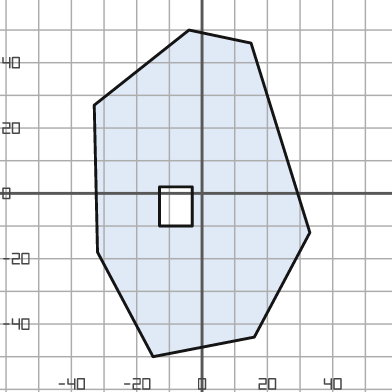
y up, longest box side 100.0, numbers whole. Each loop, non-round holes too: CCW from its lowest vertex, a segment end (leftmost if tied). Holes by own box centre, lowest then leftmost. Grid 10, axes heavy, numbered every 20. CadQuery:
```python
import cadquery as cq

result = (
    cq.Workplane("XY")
    .moveTo(-15.0, -50.0)
    .lineTo(16.0, -44.0)
    .lineTo(33.0, -12.0)
    .lineTo(15.0, 46.0)
    .lineTo(-4.0, 50.0)
    .lineTo(-33.0, 27.0)
    .lineTo(-32.0, -18.0)
    .close()
    .moveTo(-13.0, -10.0)
    .lineTo(-3.0, -10.0)
    .lineTo(-3.0, 2.0)
    .lineTo(-13.0, 2.0)
    .close()
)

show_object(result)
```